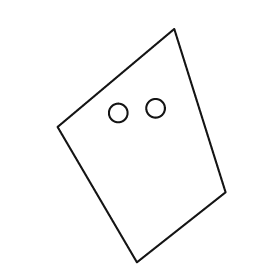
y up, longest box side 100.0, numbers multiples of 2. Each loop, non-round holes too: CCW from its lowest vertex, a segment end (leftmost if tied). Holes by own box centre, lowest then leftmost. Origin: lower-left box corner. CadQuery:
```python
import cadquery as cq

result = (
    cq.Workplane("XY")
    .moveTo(34.0, 0.0)
    .lineTo(72.0, 30.0)
    .lineTo(50.0, 100.0)
    .lineTo(0.0, 58.0)
    .close()
    .moveTo(26.0, 64.0)
    .circle(4.0)
    .moveTo(42.0, 66.0)
    .circle(4.0)
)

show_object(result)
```